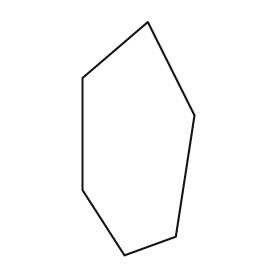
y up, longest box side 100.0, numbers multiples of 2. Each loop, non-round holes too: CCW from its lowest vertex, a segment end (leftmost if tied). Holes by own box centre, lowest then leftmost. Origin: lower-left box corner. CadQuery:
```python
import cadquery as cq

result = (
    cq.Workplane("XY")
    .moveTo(18.0, 0.0)
    .lineTo(40.0, 8.0)
    .lineTo(48.0, 60.0)
    .lineTo(28.0, 100.0)
    .lineTo(0.0, 76.0)
    .lineTo(0.0, 28.0)
    .close()
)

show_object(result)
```